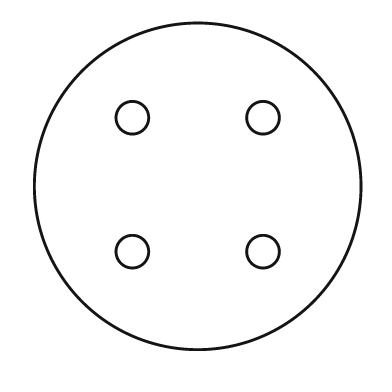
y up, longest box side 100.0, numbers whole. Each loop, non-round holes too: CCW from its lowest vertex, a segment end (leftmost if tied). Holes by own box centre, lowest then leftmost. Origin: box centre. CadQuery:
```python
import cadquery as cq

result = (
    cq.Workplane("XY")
    .moveTo(0.0, 0.0)
    .circle(50.0)
    .moveTo(-20.0, -20.0)
    .circle(5.0)
    .moveTo(20.0, -20.0)
    .circle(5.0)
    .moveTo(-20.0, 21.0)
    .circle(5.0)
    .moveTo(20.0, 21.0)
    .circle(5.0)
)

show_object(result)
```